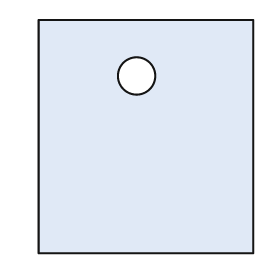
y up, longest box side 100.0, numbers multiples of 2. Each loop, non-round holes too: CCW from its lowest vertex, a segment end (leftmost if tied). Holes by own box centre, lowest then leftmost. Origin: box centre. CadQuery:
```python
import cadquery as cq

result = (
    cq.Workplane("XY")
    .moveTo(-46.0, -50.0)
    .lineTo(46.0, -50.0)
    .lineTo(46.0, 50.0)
    .lineTo(-46.0, 50.0)
    .close()
    .moveTo(-4.0, 26.0)
    .circle(8.0)
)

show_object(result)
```